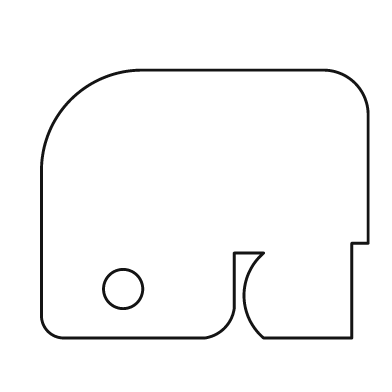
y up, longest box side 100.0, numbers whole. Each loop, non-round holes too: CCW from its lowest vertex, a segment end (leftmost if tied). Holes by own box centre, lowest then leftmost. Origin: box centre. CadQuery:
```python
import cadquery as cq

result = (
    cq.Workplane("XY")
    .moveTo(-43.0, -41.0)
    .lineTo(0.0, -41.0)
    .threePointArc((6.0, -38.0), (9.0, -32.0))
    .lineTo(9.0, -15.0)
    .lineTo(18.0, -15.0)
    .threePointArc((12.0, -28.0), (18.0, -41.0))
    .lineTo(45.0, -41.0)
    .lineTo(45.0, -12.0)
    .lineTo(50.0, -12.0)
    .lineTo(50.0, 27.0)
    .threePointArc((46.0, 37.0), (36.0, 41.0))
    .lineTo(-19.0, 41.0)
    .threePointArc((-41.0, 32.0), (-50.0, 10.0))
    .lineTo(-50.0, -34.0)
    .threePointArc((-48.0, -39.0), (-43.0, -41.0))
    .close()
    .moveTo(-25.0, -26.0)
    .circle(6.0)
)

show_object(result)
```